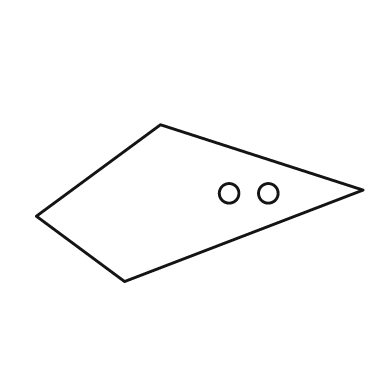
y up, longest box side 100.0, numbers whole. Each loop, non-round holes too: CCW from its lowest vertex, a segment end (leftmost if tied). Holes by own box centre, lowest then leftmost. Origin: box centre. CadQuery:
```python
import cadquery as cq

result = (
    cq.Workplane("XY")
    .moveTo(-23.0, -24.0)
    .lineTo(50.0, 4.0)
    .lineTo(-12.0, 24.0)
    .lineTo(-50.0, -4.0)
    .close()
    .moveTo(9.0, 3.0)
    .circle(3.0)
    .moveTo(21.0, 3.0)
    .circle(3.0)
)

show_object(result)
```